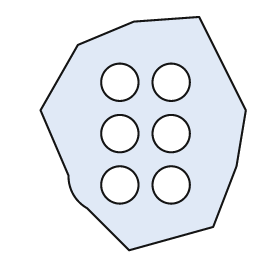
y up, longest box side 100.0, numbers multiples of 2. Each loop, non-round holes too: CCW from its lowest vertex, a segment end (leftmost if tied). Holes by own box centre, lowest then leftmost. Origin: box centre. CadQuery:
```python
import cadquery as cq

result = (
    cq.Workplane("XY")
    .moveTo(-6.0, -50.0)
    .lineTo(30.0, -40.0)
    .lineTo(40.0, -14.0)
    .lineTo(44.0, 10.0)
    .lineTo(24.0, 50.0)
    .lineTo(-4.0, 48.0)
    .lineTo(-28.0, 38.0)
    .lineTo(-44.0, 10.0)
    .lineTo(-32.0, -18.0)
    .threePointArc((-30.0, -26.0), (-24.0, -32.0))
    .close()
    .moveTo(-10.0, -22.0)
    .circle(8.0)
    .moveTo(12.0, -22.0)
    .circle(8.0)
    .moveTo(-10.0, 0.0)
    .circle(8.0)
    .moveTo(12.0, 0.0)
    .circle(8.0)
    .moveTo(-10.0, 22.0)
    .circle(8.0)
    .moveTo(12.0, 22.0)
    .circle(8.0)
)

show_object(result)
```